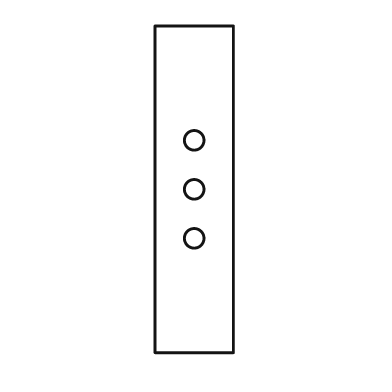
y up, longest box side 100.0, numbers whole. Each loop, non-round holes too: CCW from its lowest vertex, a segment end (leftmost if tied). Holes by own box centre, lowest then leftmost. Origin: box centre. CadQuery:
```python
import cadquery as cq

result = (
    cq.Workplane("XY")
    .moveTo(-12.0, -50.0)
    .lineTo(12.0, -50.0)
    .lineTo(12.0, 50.0)
    .lineTo(-12.0, 50.0)
    .close()
    .moveTo(0.0, -15.0)
    .circle(3.0)
    .moveTo(0.0, 0.0)
    .circle(3.0)
    .moveTo(0.0, 15.0)
    .circle(3.0)
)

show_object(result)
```